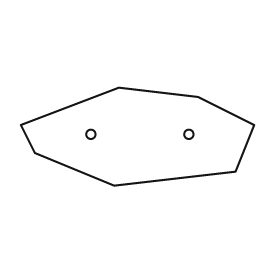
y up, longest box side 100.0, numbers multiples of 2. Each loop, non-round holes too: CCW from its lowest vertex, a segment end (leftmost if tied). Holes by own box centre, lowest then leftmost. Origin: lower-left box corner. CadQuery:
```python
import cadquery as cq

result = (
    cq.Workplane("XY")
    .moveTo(40.0, 0.0)
    .lineTo(92.0, 6.0)
    .lineTo(100.0, 26.0)
    .lineTo(76.0, 38.0)
    .lineTo(42.0, 42.0)
    .lineTo(0.0, 26.0)
    .lineTo(6.0, 14.0)
    .close()
    .moveTo(30.0, 22.0)
    .circle(2.0)
    .moveTo(72.0, 22.0)
    .circle(2.0)
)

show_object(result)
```